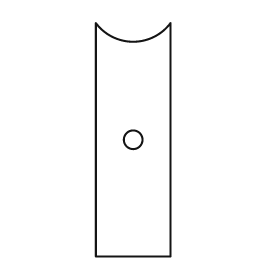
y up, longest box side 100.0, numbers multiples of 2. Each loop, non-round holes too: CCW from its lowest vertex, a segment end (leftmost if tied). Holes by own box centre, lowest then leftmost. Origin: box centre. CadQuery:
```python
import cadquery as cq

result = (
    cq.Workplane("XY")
    .moveTo(-16.0, -50.0)
    .lineTo(16.0, -50.0)
    .lineTo(16.0, 50.0)
    .threePointArc((0.0, 42.0), (-16.0, 50.0))
    .close()
    .moveTo(0.0, 0.0)
    .circle(4.0)
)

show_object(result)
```